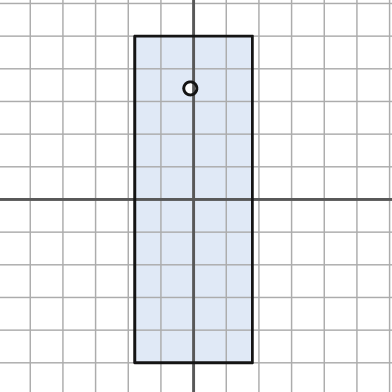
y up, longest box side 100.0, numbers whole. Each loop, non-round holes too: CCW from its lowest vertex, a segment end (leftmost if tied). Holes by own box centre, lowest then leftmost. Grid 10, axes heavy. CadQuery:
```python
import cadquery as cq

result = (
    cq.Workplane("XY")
    .moveTo(-18.0, -50.0)
    .lineTo(18.0, -50.0)
    .lineTo(18.0, 50.0)
    .lineTo(-18.0, 50.0)
    .close()
    .moveTo(-1.0, 34.0)
    .circle(2.0)
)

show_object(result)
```